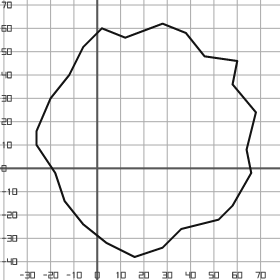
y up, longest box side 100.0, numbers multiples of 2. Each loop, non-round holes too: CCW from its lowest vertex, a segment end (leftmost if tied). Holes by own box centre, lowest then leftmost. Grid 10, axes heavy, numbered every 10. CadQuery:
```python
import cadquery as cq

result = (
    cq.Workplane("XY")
    .moveTo(16.0, -38.0)
    .lineTo(28.0, -34.0)
    .lineTo(36.0, -26.0)
    .lineTo(52.0, -22.0)
    .lineTo(58.0, -16.0)
    .lineTo(66.0, -2.0)
    .lineTo(64.0, 8.0)
    .lineTo(68.0, 24.0)
    .lineTo(58.0, 36.0)
    .lineTo(60.0, 46.0)
    .lineTo(46.0, 48.0)
    .lineTo(38.0, 58.0)
    .lineTo(28.0, 62.0)
    .lineTo(12.0, 56.0)
    .lineTo(2.0, 60.0)
    .lineTo(-6.0, 52.0)
    .lineTo(-12.0, 40.0)
    .lineTo(-20.0, 30.0)
    .lineTo(-26.0, 16.0)
    .lineTo(-26.0, 10.0)
    .lineTo(-18.0, -2.0)
    .lineTo(-14.0, -14.0)
    .lineTo(-6.0, -24.0)
    .lineTo(4.0, -32.0)
    .close()
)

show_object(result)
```